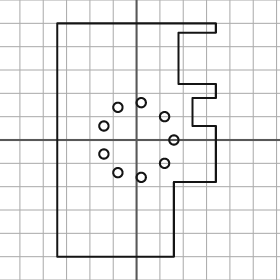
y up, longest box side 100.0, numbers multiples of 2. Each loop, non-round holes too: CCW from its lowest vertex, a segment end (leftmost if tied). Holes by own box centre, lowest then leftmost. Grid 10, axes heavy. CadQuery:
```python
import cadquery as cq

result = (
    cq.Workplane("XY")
    .moveTo(-34.0, -50.0)
    .lineTo(16.0, -50.0)
    .lineTo(16.0, -18.0)
    .lineTo(34.0, -18.0)
    .lineTo(34.0, 6.0)
    .lineTo(24.0, 6.0)
    .lineTo(24.0, 18.0)
    .lineTo(34.0, 18.0)
    .lineTo(34.0, 24.0)
    .lineTo(18.0, 24.0)
    .lineTo(18.0, 46.0)
    .lineTo(34.0, 46.0)
    .lineTo(34.0, 50.0)
    .lineTo(-34.0, 50.0)
    .close()
    .moveTo(2.0, -16.0)
    .circle(2.0)
    .moveTo(-8.0, -14.0)
    .circle(2.0)
    .moveTo(12.0, -10.0)
    .circle(2.0)
    .moveTo(-14.0, -6.0)
    .circle(2.0)
    .moveTo(16.0, 0.0)
    .circle(2.0)
    .moveTo(-14.0, 6.0)
    .circle(2.0)
    .moveTo(12.0, 10.0)
    .circle(2.0)
    .moveTo(-8.0, 14.0)
    .circle(2.0)
    .moveTo(2.0, 16.0)
    .circle(2.0)
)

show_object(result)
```